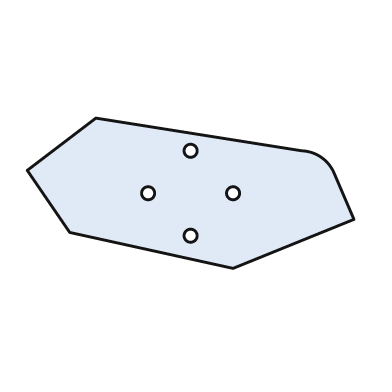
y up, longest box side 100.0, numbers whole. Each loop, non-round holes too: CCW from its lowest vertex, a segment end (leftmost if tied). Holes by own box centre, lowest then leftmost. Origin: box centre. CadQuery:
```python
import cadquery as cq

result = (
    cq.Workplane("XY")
    .moveTo(13.0, -23.0)
    .lineTo(50.0, -8.0)
    .lineTo(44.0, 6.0)
    .threePointArc((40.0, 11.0), (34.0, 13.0))
    .lineTo(-29.0, 23.0)
    .lineTo(-50.0, 7.0)
    .lineTo(-37.0, -12.0)
    .close()
    .moveTo(0.0, -13.0)
    .circle(2.0)
    .moveTo(-13.0, 0.0)
    .circle(2.0)
    .moveTo(13.0, 0.0)
    .circle(2.0)
    .moveTo(0.0, 13.0)
    .circle(2.0)
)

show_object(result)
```